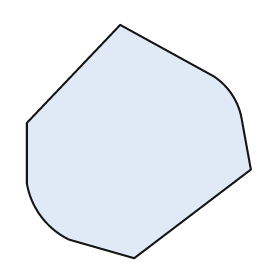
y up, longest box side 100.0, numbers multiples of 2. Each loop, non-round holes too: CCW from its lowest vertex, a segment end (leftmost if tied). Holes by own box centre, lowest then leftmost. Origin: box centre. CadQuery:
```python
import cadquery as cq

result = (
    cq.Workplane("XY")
    .moveTo(-2.0, -50.0)
    .lineTo(48.0, -12.0)
    .lineTo(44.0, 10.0)
    .threePointArc((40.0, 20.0), (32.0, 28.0))
    .lineTo(-8.0, 50.0)
    .lineTo(-48.0, 8.0)
    .lineTo(-48.0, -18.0)
    .threePointArc((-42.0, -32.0), (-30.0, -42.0))
    .close()
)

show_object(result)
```